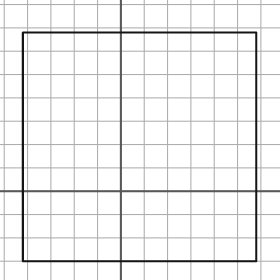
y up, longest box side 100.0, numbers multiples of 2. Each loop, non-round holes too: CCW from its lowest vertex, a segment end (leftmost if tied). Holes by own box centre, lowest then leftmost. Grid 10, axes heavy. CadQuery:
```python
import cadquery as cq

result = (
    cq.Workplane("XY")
    .moveTo(-42.0, -30.0)
    .lineTo(58.0, -30.0)
    .lineTo(58.0, 68.0)
    .lineTo(-42.0, 68.0)
    .close()
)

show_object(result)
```